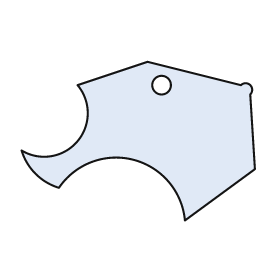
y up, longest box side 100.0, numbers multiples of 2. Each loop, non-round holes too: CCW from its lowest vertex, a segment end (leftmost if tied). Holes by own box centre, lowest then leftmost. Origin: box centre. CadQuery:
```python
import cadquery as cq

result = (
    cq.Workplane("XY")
    .moveTo(20.0, -34.0)
    .lineTo(50.0, -12.0)
    .lineTo(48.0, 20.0)
    .threePointArc((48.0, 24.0), (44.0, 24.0))
    .lineTo(4.0, 34.0)
    .lineTo(-26.0, 24.0)
    .threePointArc((-26.0, 0.0), (-50.0, -4.0))
    .threePointArc((-44.0, -14.0), (-34.0, -20.0))
    .threePointArc((-2.0, -8.0), (20.0, -34.0))
    .close()
    .moveTo(10.0, 24.0)
    .circle(4.0)
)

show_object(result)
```